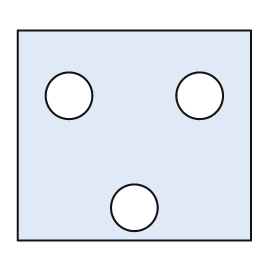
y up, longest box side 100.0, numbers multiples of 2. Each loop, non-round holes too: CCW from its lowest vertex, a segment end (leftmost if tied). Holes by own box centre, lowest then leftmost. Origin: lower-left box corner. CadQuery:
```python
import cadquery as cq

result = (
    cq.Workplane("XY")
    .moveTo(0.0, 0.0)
    .lineTo(100.0, 0.0)
    .lineTo(100.0, 90.0)
    .lineTo(0.0, 90.0)
    .close()
    .moveTo(50.0, 14.0)
    .circle(10.0)
    .moveTo(22.0, 62.0)
    .circle(10.0)
    .moveTo(78.0, 62.0)
    .circle(10.0)
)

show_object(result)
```